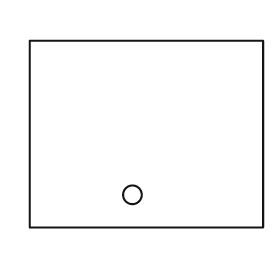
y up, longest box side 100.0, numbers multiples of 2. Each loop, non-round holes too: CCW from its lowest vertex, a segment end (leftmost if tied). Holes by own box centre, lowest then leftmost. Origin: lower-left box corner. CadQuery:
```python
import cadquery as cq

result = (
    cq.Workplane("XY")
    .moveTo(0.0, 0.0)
    .lineTo(100.0, 0.0)
    .lineTo(100.0, 80.0)
    .lineTo(0.0, 80.0)
    .close()
    .moveTo(44.0, 14.0)
    .circle(4.0)
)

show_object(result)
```